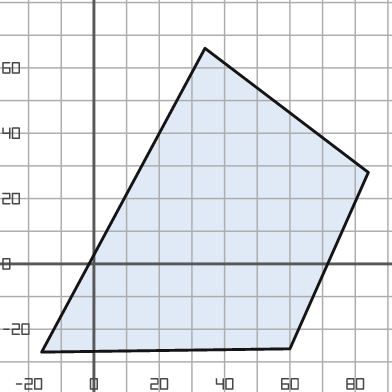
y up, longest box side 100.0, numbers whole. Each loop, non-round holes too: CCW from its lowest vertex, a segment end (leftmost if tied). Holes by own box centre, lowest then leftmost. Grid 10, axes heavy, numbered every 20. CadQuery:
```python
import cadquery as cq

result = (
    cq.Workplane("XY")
    .moveTo(-16.0, -27.0)
    .lineTo(60.0, -26.0)
    .lineTo(84.0, 28.0)
    .lineTo(34.0, 66.0)
    .close()
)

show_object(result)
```